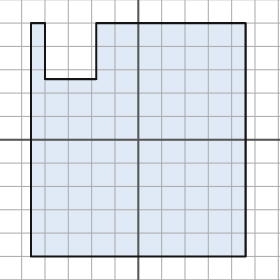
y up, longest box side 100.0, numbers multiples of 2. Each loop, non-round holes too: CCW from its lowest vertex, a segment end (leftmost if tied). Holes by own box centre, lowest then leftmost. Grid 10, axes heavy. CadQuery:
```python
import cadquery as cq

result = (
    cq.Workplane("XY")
    .moveTo(-46.0, -50.0)
    .lineTo(46.0, -50.0)
    .lineTo(46.0, 50.0)
    .lineTo(-18.0, 50.0)
    .lineTo(-18.0, 26.0)
    .lineTo(-40.0, 26.0)
    .lineTo(-40.0, 50.0)
    .lineTo(-46.0, 50.0)
    .close()
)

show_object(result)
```